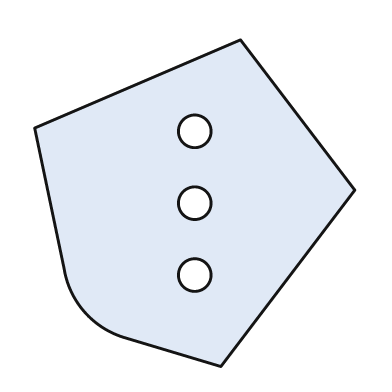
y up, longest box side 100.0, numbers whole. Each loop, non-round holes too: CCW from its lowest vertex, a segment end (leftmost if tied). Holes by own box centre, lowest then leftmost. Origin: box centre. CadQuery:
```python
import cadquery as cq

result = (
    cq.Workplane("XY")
    .moveTo(8.0, -50.0)
    .lineTo(49.0, 4.0)
    .lineTo(14.0, 50.0)
    .lineTo(-49.0, 23.0)
    .lineTo(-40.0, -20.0)
    .threePointArc((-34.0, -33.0), (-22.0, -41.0))
    .close()
    .moveTo(0.0, -22.0)
    .circle(5.0)
    .moveTo(0.0, 0.0)
    .circle(5.0)
    .moveTo(0.0, 22.0)
    .circle(5.0)
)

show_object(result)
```